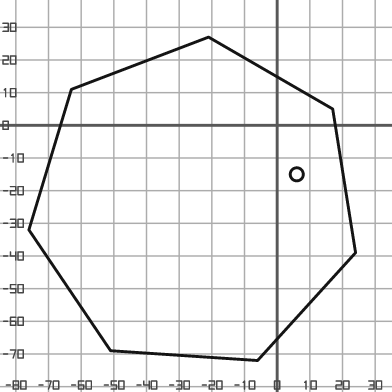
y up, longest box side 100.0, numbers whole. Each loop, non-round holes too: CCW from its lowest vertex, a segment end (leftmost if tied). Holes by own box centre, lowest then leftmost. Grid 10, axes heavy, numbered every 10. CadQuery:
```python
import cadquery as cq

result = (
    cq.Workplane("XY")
    .moveTo(-6.0, -72.0)
    .lineTo(24.0, -39.0)
    .lineTo(17.0, 5.0)
    .lineTo(-21.0, 27.0)
    .lineTo(-63.0, 11.0)
    .lineTo(-76.0, -32.0)
    .lineTo(-51.0, -69.0)
    .close()
    .moveTo(6.0, -15.0)
    .circle(2.0)
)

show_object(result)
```